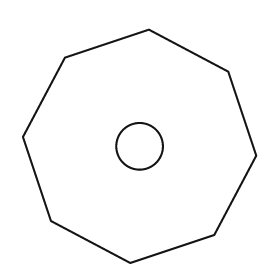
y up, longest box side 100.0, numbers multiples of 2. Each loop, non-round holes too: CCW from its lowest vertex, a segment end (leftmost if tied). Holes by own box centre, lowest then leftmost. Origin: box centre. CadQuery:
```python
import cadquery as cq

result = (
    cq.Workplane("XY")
    .moveTo(-4.0, -50.0)
    .lineTo(32.0, -38.0)
    .lineTo(50.0, -4.0)
    .lineTo(38.0, 32.0)
    .lineTo(4.0, 50.0)
    .lineTo(-32.0, 38.0)
    .lineTo(-50.0, 4.0)
    .lineTo(-38.0, -32.0)
    .close()
    .moveTo(0.0, 0.0)
    .circle(10.0)
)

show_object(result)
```